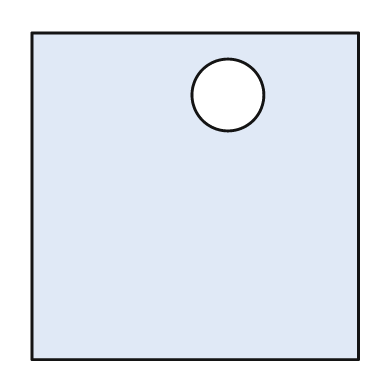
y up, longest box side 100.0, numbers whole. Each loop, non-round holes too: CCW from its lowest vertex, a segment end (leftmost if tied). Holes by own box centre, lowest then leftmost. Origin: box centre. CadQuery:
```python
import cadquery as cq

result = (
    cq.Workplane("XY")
    .moveTo(-50.0, -50.0)
    .lineTo(50.0, -50.0)
    .lineTo(50.0, 50.0)
    .lineTo(-50.0, 50.0)
    .close()
    .moveTo(10.0, 31.0)
    .circle(11.0)
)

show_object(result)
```